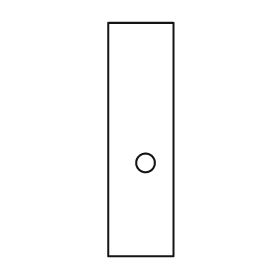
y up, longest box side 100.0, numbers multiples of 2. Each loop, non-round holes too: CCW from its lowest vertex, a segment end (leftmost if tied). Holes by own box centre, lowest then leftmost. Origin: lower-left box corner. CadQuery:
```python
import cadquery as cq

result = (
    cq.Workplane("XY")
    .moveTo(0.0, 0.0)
    .lineTo(28.0, 0.0)
    .lineTo(28.0, 100.0)
    .lineTo(0.0, 100.0)
    .close()
    .moveTo(16.0, 40.0)
    .circle(4.0)
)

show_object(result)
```